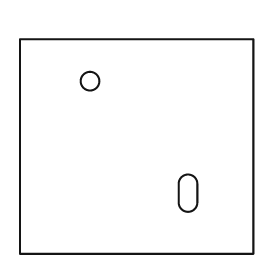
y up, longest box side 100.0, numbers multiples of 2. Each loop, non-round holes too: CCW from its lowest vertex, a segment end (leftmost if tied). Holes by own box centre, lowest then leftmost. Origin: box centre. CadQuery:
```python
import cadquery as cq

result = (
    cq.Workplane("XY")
    .moveTo(-50.0, -46.0)
    .lineTo(50.0, -46.0)
    .lineTo(50.0, 46.0)
    .lineTo(-50.0, 46.0)
    .close()
    .moveTo(18.0, -24.0)
    .threePointArc((22.0, -28.0), (26.0, -24.0))
    .lineTo(26.0, -16.0)
    .threePointArc((22.0, -12.0), (18.0, -16.0))
    .close()
    .moveTo(-20.0, 28.0)
    .circle(4.0)
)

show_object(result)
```